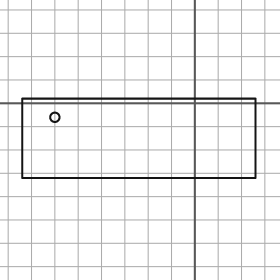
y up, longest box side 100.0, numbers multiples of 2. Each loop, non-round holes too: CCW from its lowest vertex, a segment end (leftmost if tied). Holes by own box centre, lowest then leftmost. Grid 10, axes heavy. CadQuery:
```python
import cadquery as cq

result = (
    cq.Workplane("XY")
    .moveTo(-74.0, -32.0)
    .lineTo(26.0, -32.0)
    .lineTo(26.0, 2.0)
    .lineTo(-74.0, 2.0)
    .close()
    .moveTo(-60.0, -6.0)
    .circle(2.0)
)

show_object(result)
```